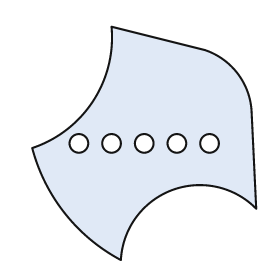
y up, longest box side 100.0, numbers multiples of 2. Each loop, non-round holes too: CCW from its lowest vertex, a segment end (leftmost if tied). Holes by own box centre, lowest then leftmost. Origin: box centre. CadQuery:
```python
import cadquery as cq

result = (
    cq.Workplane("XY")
    .moveTo(-10.0, -50.0)
    .threePointArc((12.0, -20.0), (48.0, -28.0))
    .lineTo(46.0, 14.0)
    .threePointArc((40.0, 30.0), (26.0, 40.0))
    .lineTo(-14.0, 50.0)
    .threePointArc((-22.0, 18.0), (-48.0, -2.0))
    .threePointArc((-34.0, -30.0), (-10.0, -50.0))
    .close()
    .moveTo(-28.0, 0.0)
    .circle(4.0)
    .moveTo(-14.0, 0.0)
    .circle(4.0)
    .moveTo(0.0, 0.0)
    .circle(4.0)
    .moveTo(14.0, 0.0)
    .circle(4.0)
    .moveTo(28.0, 0.0)
    .circle(4.0)
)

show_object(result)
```